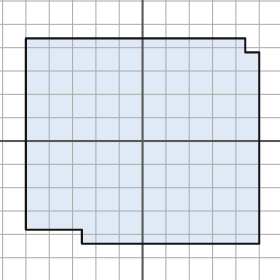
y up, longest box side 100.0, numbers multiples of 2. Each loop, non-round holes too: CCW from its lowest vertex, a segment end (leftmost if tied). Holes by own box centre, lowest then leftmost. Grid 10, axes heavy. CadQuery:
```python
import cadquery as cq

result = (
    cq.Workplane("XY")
    .moveTo(-26.0, -44.0)
    .lineTo(50.0, -44.0)
    .lineTo(50.0, 38.0)
    .lineTo(44.0, 38.0)
    .lineTo(44.0, 44.0)
    .lineTo(-50.0, 44.0)
    .lineTo(-50.0, -38.0)
    .lineTo(-26.0, -38.0)
    .close()
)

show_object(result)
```